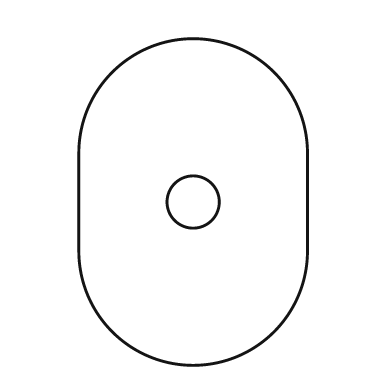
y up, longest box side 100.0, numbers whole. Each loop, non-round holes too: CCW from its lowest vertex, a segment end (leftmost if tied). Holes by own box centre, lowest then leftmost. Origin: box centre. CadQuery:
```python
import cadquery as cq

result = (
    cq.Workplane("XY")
    .moveTo(-35.0, -15.0)
    .threePointArc((0.0, -50.0), (35.0, -15.0))
    .lineTo(35.0, 15.0)
    .threePointArc((0.0, 50.0), (-35.0, 15.0))
    .close()
    .moveTo(0.0, 0.0)
    .circle(8.0)
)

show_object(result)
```